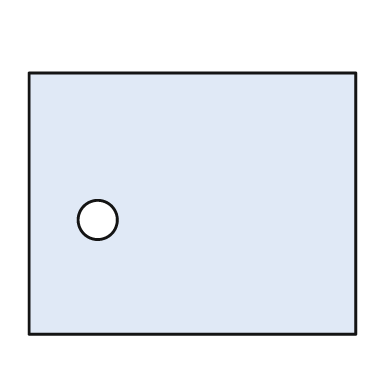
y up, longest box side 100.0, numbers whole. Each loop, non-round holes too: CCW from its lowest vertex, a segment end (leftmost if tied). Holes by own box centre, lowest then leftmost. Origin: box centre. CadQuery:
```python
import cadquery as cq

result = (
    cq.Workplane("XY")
    .moveTo(-50.0, -40.0)
    .lineTo(50.0, -40.0)
    .lineTo(50.0, 40.0)
    .lineTo(-50.0, 40.0)
    .close()
    .moveTo(-29.0, -5.0)
    .circle(6.0)
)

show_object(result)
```